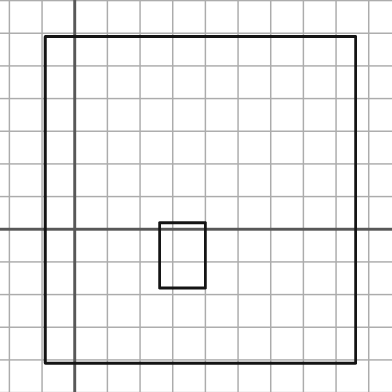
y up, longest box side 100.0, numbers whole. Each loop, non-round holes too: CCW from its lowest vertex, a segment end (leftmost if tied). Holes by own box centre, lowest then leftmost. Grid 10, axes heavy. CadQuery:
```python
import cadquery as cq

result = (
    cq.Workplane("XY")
    .moveTo(-9.0, -41.0)
    .lineTo(86.0, -41.0)
    .lineTo(86.0, 59.0)
    .lineTo(-9.0, 59.0)
    .close()
    .moveTo(26.0, -18.0)
    .lineTo(40.0, -18.0)
    .lineTo(40.0, 2.0)
    .lineTo(26.0, 2.0)
    .close()
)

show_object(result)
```